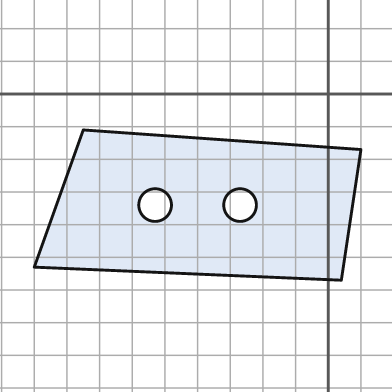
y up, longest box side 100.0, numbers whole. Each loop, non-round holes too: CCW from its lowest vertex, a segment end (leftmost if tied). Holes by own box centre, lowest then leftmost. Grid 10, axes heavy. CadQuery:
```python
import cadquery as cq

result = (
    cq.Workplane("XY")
    .moveTo(4.0, -57.0)
    .lineTo(10.0, -17.0)
    .lineTo(-75.0, -11.0)
    .lineTo(-90.0, -53.0)
    .close()
    .moveTo(-53.0, -34.0)
    .circle(5.0)
    .moveTo(-27.0, -34.0)
    .circle(5.0)
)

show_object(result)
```